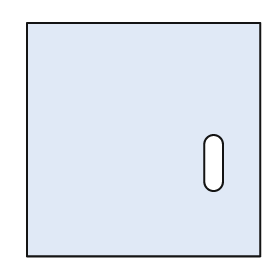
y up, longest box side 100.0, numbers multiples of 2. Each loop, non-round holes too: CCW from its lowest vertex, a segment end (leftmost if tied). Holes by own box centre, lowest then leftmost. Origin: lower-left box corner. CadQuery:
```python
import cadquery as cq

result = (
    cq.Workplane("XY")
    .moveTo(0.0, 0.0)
    .lineTo(100.0, 0.0)
    .lineTo(100.0, 100.0)
    .lineTo(0.0, 100.0)
    .close()
    .moveTo(76.0, 32.0)
    .threePointArc((80.0, 28.0), (84.0, 32.0))
    .lineTo(84.0, 48.0)
    .threePointArc((80.0, 52.0), (76.0, 48.0))
    .close()
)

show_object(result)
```